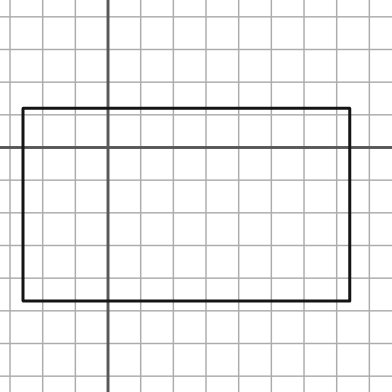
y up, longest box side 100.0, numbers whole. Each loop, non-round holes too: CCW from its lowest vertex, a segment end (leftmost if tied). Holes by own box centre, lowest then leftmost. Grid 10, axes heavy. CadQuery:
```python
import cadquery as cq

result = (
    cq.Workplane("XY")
    .moveTo(-26.0, -47.0)
    .lineTo(74.0, -47.0)
    .lineTo(74.0, 12.0)
    .lineTo(-26.0, 12.0)
    .close()
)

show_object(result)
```